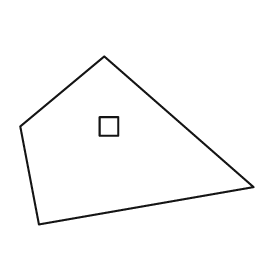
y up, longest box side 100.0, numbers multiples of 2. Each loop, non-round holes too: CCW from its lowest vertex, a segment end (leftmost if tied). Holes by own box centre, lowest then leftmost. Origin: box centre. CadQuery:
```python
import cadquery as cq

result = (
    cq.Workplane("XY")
    .moveTo(-42.0, -36.0)
    .lineTo(50.0, -20.0)
    .lineTo(-14.0, 36.0)
    .lineTo(-50.0, 6.0)
    .close()
    .moveTo(-16.0, 2.0)
    .lineTo(-8.0, 2.0)
    .lineTo(-8.0, 10.0)
    .lineTo(-16.0, 10.0)
    .close()
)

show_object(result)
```